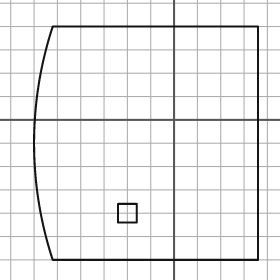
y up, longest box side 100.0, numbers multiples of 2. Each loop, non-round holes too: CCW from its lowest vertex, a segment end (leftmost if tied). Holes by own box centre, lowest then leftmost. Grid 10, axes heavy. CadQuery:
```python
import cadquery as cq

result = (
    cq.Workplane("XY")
    .moveTo(-52.0, -60.0)
    .lineTo(36.0, -60.0)
    .lineTo(36.0, 40.0)
    .lineTo(-52.0, 40.0)
    .threePointArc((-60.0, -10.0), (-52.0, -60.0))
    .close()
    .moveTo(-24.0, -44.0)
    .lineTo(-16.0, -44.0)
    .lineTo(-16.0, -36.0)
    .lineTo(-24.0, -36.0)
    .close()
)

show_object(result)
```